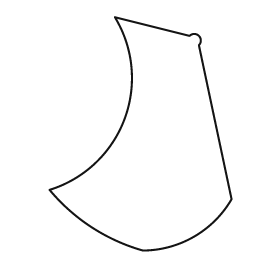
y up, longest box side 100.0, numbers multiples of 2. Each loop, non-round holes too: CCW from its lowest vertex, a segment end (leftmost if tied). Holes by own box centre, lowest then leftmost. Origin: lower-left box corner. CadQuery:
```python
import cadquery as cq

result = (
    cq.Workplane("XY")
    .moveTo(40.0, 0.0)
    .threePointArc((62.0, 6.0), (78.0, 22.0))
    .lineTo(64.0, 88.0)
    .threePointArc((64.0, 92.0), (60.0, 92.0))
    .lineTo(28.0, 100.0)
    .threePointArc((32.0, 56.0), (0.0, 26.0))
    .threePointArc((18.0, 10.0), (40.0, 0.0))
    .close()
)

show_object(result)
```